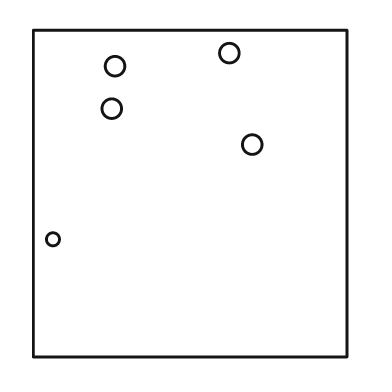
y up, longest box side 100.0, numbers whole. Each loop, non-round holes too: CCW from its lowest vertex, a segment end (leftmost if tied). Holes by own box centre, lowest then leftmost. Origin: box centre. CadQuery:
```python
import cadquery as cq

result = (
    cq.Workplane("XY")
    .moveTo(-48.0, -50.0)
    .lineTo(48.0, -50.0)
    .lineTo(48.0, 50.0)
    .lineTo(-48.0, 50.0)
    .close()
    .moveTo(-42.0, -14.0)
    .circle(2.0)
    .moveTo(19.0, 15.0)
    .circle(3.0)
    .moveTo(-24.0, 26.0)
    .circle(3.0)
    .moveTo(-23.0, 39.0)
    .circle(3.0)
    .moveTo(12.0, 43.0)
    .circle(3.0)
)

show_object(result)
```